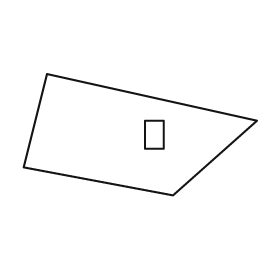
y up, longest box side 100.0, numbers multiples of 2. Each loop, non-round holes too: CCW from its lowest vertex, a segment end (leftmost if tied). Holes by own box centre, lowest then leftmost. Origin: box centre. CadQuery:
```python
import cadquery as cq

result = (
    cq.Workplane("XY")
    .moveTo(14.0, -26.0)
    .lineTo(50.0, 6.0)
    .lineTo(-40.0, 26.0)
    .lineTo(-50.0, -14.0)
    .close()
    .moveTo(2.0, -6.0)
    .lineTo(10.0, -6.0)
    .lineTo(10.0, 6.0)
    .lineTo(2.0, 6.0)
    .close()
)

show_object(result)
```